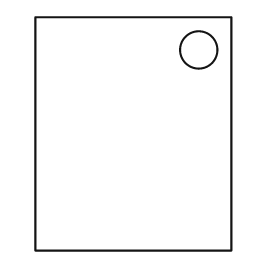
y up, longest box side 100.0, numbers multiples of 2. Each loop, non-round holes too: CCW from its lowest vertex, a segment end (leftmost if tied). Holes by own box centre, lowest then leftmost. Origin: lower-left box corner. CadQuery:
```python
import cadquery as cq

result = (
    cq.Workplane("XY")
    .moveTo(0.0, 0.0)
    .lineTo(84.0, 0.0)
    .lineTo(84.0, 100.0)
    .lineTo(0.0, 100.0)
    .close()
    .moveTo(70.0, 86.0)
    .circle(8.0)
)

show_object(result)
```